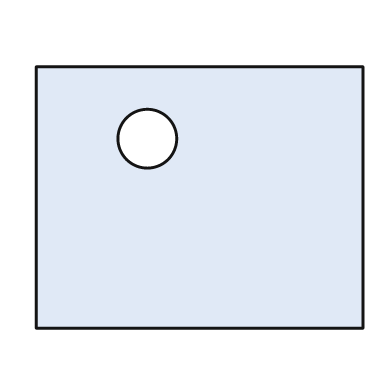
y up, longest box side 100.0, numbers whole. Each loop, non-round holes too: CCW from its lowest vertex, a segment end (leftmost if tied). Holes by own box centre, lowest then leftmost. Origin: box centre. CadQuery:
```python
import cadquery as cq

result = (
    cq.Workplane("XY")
    .moveTo(-50.0, -40.0)
    .lineTo(50.0, -40.0)
    .lineTo(50.0, 40.0)
    .lineTo(-50.0, 40.0)
    .close()
    .moveTo(-16.0, 18.0)
    .circle(9.0)
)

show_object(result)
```